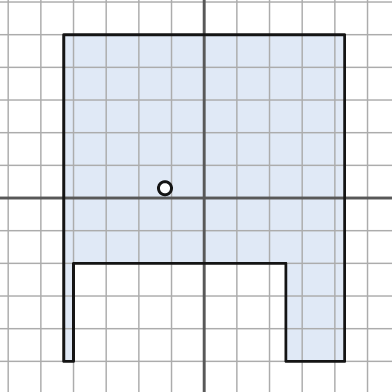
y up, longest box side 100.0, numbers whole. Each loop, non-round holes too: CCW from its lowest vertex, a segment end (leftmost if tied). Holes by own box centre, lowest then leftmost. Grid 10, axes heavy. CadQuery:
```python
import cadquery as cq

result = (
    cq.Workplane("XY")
    .moveTo(-43.0, -50.0)
    .lineTo(-40.0, -50.0)
    .lineTo(-40.0, -20.0)
    .lineTo(25.0, -20.0)
    .lineTo(25.0, -50.0)
    .lineTo(43.0, -50.0)
    .lineTo(43.0, 50.0)
    .lineTo(-43.0, 50.0)
    .close()
    .moveTo(-12.0, 3.0)
    .circle(2.0)
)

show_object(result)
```